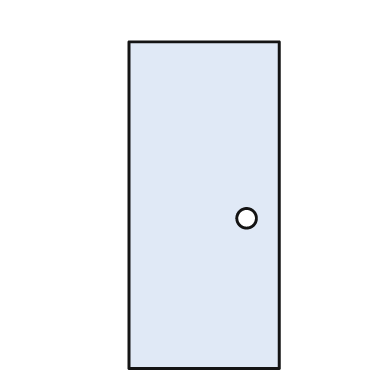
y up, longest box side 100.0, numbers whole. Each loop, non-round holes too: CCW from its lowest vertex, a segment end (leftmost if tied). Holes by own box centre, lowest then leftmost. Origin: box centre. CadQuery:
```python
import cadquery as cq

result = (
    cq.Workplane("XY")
    .moveTo(-23.0, -50.0)
    .lineTo(23.0, -50.0)
    .lineTo(23.0, 50.0)
    .lineTo(-23.0, 50.0)
    .close()
    .moveTo(13.0, -4.0)
    .circle(3.0)
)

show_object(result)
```